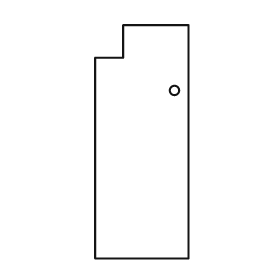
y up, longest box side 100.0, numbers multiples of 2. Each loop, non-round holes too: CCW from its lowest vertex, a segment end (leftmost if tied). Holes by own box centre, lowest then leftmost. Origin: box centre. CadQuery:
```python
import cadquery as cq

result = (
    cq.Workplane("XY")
    .moveTo(-20.0, -50.0)
    .lineTo(20.0, -50.0)
    .lineTo(20.0, 50.0)
    .lineTo(-8.0, 50.0)
    .lineTo(-8.0, 36.0)
    .lineTo(-20.0, 36.0)
    .close()
    .moveTo(14.0, 22.0)
    .circle(2.0)
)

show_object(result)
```